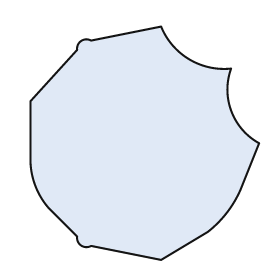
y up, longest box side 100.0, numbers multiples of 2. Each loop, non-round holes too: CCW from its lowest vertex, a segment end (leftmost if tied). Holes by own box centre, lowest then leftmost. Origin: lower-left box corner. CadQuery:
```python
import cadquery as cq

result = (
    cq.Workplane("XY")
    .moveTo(56.0, 0.0)
    .lineTo(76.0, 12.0)
    .threePointArc((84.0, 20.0), (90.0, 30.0))
    .lineTo(98.0, 50.0)
    .threePointArc((86.0, 64.0), (86.0, 82.0))
    .threePointArc((68.0, 86.0), (56.0, 100.0))
    .lineTo(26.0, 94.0)
    .threePointArc((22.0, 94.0), (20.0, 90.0))
    .lineTo(0.0, 68.0)
    .lineTo(0.0, 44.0)
    .threePointArc((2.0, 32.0), (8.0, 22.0))
    .lineTo(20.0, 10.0)
    .threePointArc((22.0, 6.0), (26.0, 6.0))
    .close()
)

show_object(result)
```